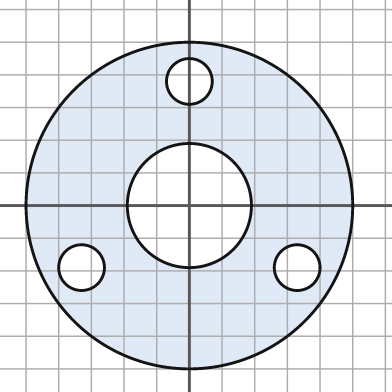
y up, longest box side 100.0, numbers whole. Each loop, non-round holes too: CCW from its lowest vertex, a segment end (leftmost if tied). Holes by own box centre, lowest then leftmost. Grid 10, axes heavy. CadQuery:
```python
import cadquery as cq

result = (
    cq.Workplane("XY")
    .moveTo(0.0, 0.0)
    .circle(50.0)
    .moveTo(-33.0, -19.0)
    .circle(7.0)
    .moveTo(33.0, -19.0)
    .circle(7.0)
    .moveTo(0.0, 0.0)
    .circle(19.0)
    .moveTo(0.0, 38.0)
    .circle(7.0)
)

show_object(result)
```